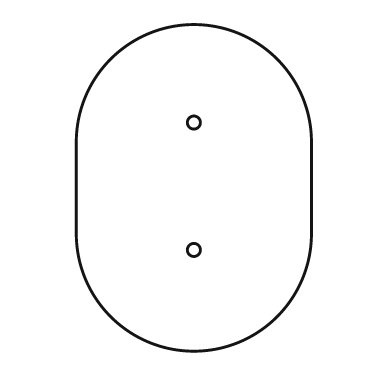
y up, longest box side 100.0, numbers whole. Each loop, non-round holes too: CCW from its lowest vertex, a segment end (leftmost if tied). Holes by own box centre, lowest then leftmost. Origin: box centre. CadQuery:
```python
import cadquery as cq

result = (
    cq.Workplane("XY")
    .moveTo(-36.0, -14.0)
    .threePointArc((0.0, -50.0), (36.0, -14.0))
    .lineTo(36.0, 14.0)
    .threePointArc((0.0, 50.0), (-36.0, 14.0))
    .close()
    .moveTo(0.0, -19.0)
    .circle(2.0)
    .moveTo(0.0, 20.0)
    .circle(2.0)
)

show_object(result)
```